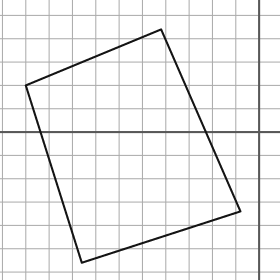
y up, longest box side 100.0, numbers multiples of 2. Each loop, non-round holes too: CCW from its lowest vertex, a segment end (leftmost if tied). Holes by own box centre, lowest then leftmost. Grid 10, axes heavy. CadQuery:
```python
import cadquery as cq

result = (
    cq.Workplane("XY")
    .moveTo(-76.0, -56.0)
    .lineTo(-8.0, -34.0)
    .lineTo(-42.0, 44.0)
    .lineTo(-100.0, 20.0)
    .close()
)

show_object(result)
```